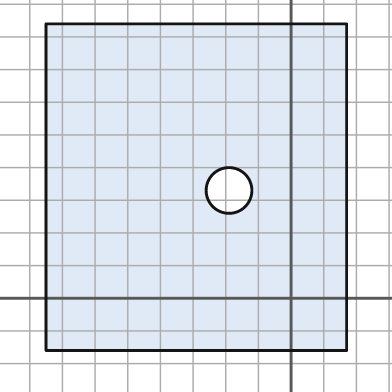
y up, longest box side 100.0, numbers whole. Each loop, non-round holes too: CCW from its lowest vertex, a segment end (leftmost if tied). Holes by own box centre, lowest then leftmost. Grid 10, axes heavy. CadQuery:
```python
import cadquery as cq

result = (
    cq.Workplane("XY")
    .moveTo(-75.0, -16.0)
    .lineTo(17.0, -16.0)
    .lineTo(17.0, 84.0)
    .lineTo(-75.0, 84.0)
    .close()
    .moveTo(-19.0, 33.0)
    .circle(7.0)
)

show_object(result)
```